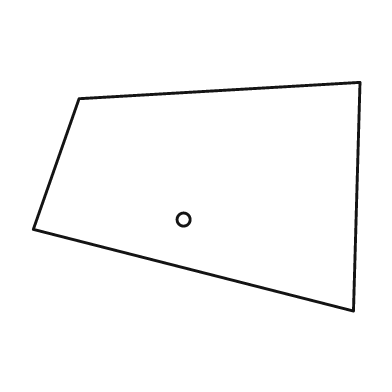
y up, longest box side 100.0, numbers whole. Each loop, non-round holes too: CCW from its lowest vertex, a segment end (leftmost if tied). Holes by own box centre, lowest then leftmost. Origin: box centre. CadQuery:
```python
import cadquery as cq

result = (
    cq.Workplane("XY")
    .moveTo(48.0, -35.0)
    .lineTo(50.0, 35.0)
    .lineTo(-36.0, 30.0)
    .lineTo(-50.0, -10.0)
    .close()
    .moveTo(-4.0, -7.0)
    .circle(2.0)
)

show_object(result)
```